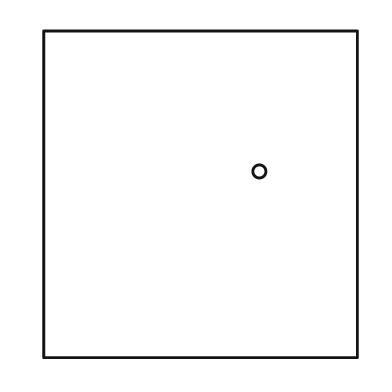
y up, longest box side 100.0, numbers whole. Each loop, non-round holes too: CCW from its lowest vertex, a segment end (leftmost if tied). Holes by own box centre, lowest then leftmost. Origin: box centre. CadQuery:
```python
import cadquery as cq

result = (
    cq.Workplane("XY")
    .moveTo(-48.0, -50.0)
    .lineTo(48.0, -50.0)
    .lineTo(48.0, 50.0)
    .lineTo(-48.0, 50.0)
    .close()
    .moveTo(18.0, 7.0)
    .circle(2.0)
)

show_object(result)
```